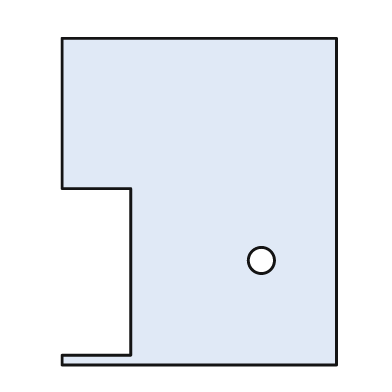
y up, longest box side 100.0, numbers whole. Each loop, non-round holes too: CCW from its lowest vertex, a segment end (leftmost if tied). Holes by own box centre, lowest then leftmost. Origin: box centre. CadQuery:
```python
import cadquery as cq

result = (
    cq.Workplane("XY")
    .moveTo(-42.0, -50.0)
    .lineTo(42.0, -50.0)
    .lineTo(42.0, 50.0)
    .lineTo(-42.0, 50.0)
    .lineTo(-42.0, 4.0)
    .lineTo(-21.0, 4.0)
    .lineTo(-21.0, -47.0)
    .lineTo(-42.0, -47.0)
    .close()
    .moveTo(19.0, -18.0)
    .circle(4.0)
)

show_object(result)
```